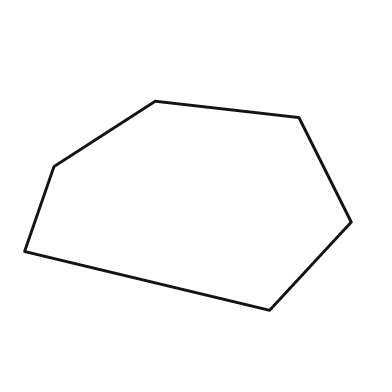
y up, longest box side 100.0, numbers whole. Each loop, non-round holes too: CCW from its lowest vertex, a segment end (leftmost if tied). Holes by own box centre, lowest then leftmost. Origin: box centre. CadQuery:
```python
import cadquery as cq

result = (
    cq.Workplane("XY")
    .moveTo(25.0, -32.0)
    .lineTo(50.0, -5.0)
    .lineTo(34.0, 27.0)
    .lineTo(-10.0, 32.0)
    .lineTo(-41.0, 12.0)
    .lineTo(-50.0, -14.0)
    .close()
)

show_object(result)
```